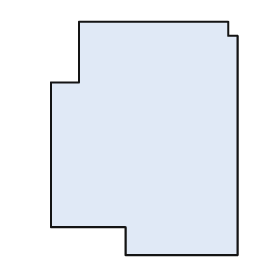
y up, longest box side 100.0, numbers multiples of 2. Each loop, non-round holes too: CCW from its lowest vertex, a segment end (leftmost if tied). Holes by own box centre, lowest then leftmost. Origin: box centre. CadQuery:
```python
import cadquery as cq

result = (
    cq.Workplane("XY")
    .moveTo(-8.0, -50.0)
    .lineTo(40.0, -50.0)
    .lineTo(40.0, 44.0)
    .lineTo(36.0, 44.0)
    .lineTo(36.0, 50.0)
    .lineTo(-28.0, 50.0)
    .lineTo(-28.0, 24.0)
    .lineTo(-40.0, 24.0)
    .lineTo(-40.0, -38.0)
    .lineTo(-8.0, -38.0)
    .close()
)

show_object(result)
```